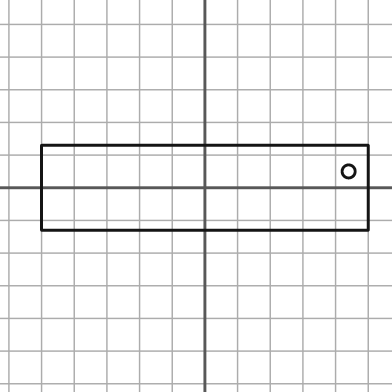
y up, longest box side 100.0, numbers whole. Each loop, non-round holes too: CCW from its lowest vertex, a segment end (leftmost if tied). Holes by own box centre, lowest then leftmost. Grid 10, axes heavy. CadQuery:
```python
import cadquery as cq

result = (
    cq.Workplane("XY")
    .moveTo(-50.0, -13.0)
    .lineTo(50.0, -13.0)
    .lineTo(50.0, 13.0)
    .lineTo(-50.0, 13.0)
    .close()
    .moveTo(44.0, 5.0)
    .circle(2.0)
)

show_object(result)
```